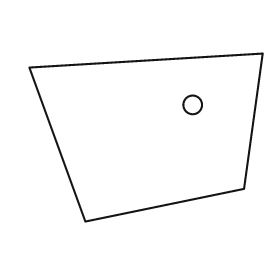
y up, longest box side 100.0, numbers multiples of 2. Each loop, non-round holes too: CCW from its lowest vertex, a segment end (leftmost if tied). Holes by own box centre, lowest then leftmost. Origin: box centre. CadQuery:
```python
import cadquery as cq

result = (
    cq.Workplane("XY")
    .moveTo(-26.0, -36.0)
    .lineTo(42.0, -22.0)
    .lineTo(50.0, 36.0)
    .lineTo(-50.0, 30.0)
    .close()
    .moveTo(20.0, 14.0)
    .circle(4.0)
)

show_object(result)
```